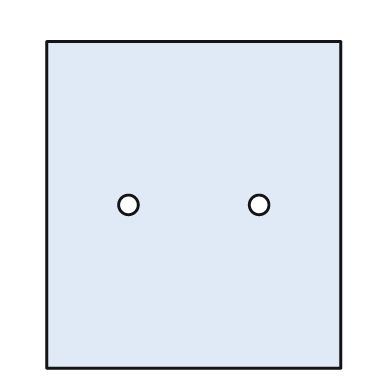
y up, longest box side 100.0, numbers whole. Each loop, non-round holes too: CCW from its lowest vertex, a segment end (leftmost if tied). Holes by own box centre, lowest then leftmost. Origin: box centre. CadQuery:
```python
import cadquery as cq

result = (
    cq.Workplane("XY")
    .moveTo(-45.0, -50.0)
    .lineTo(45.0, -50.0)
    .lineTo(45.0, 50.0)
    .lineTo(-45.0, 50.0)
    .close()
    .moveTo(-20.0, 0.0)
    .circle(3.0)
    .moveTo(20.0, 0.0)
    .circle(3.0)
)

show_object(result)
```